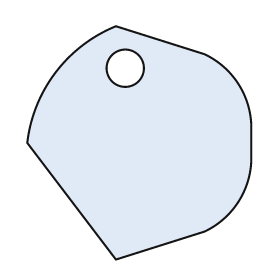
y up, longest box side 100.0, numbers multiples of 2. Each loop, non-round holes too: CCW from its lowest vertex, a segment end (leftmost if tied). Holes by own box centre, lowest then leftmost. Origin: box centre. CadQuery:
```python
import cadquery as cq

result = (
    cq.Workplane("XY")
    .moveTo(-10.0, -50.0)
    .lineTo(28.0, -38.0)
    .threePointArc((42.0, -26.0), (48.0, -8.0))
    .lineTo(48.0, 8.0)
    .threePointArc((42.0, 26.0), (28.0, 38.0))
    .lineTo(-10.0, 50.0)
    .threePointArc((-36.0, 30.0), (-48.0, 0.0))
    .close()
    .moveTo(-6.0, 32.0)
    .circle(8.0)
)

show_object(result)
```